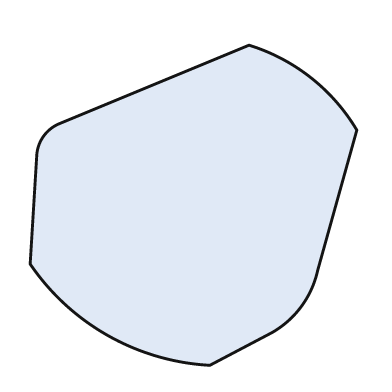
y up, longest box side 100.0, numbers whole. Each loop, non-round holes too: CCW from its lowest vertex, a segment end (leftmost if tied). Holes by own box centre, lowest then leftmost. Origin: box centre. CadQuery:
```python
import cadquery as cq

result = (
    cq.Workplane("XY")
    .moveTo(5.0, -49.0)
    .lineTo(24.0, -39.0)
    .threePointArc((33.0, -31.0), (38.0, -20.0))
    .lineTo(50.0, 23.0)
    .threePointArc((36.0, 39.0), (17.0, 49.0))
    .lineTo(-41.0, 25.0)
    .threePointArc((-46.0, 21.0), (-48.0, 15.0))
    .lineTo(-50.0, -18.0)
    .threePointArc((-26.0, -40.0), (5.0, -49.0))
    .close()
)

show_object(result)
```